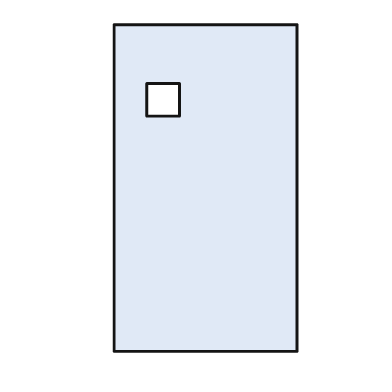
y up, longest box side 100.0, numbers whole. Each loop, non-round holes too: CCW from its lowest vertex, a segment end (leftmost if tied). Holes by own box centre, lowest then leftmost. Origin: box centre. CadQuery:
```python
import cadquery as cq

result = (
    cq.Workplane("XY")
    .moveTo(-28.0, -50.0)
    .lineTo(28.0, -50.0)
    .lineTo(28.0, 50.0)
    .lineTo(-28.0, 50.0)
    .close()
    .moveTo(-18.0, 22.0)
    .lineTo(-8.0, 22.0)
    .lineTo(-8.0, 32.0)
    .lineTo(-18.0, 32.0)
    .close()
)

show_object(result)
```